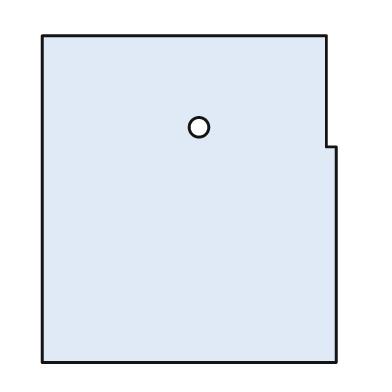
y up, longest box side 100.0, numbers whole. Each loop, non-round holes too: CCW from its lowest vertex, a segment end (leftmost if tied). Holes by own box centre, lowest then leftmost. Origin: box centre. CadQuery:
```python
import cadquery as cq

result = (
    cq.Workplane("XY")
    .moveTo(-45.0, -50.0)
    .lineTo(45.0, -50.0)
    .lineTo(45.0, 16.0)
    .lineTo(42.0, 16.0)
    .lineTo(42.0, 50.0)
    .lineTo(-45.0, 50.0)
    .close()
    .moveTo(3.0, 22.0)
    .circle(3.0)
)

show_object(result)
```